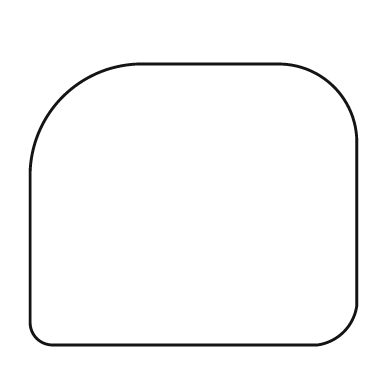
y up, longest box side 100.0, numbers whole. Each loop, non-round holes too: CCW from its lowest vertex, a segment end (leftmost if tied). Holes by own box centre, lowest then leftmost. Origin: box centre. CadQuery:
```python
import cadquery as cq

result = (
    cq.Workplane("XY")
    .moveTo(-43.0, -43.0)
    .lineTo(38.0, -43.0)
    .threePointArc((46.0, -39.0), (50.0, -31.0))
    .lineTo(50.0, 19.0)
    .threePointArc((43.0, 36.0), (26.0, 43.0))
    .lineTo(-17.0, 43.0)
    .threePointArc((-40.0, 33.0), (-50.0, 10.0))
    .lineTo(-50.0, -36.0)
    .threePointArc((-48.0, -41.0), (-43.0, -43.0))
    .close()
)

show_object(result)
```